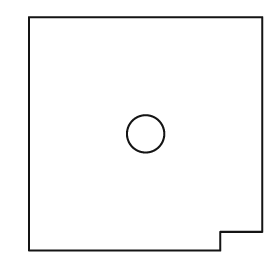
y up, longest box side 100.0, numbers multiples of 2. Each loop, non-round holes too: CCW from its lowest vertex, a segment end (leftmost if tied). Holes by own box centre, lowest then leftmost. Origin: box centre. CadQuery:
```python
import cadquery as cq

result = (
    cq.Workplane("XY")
    .moveTo(-50.0, -50.0)
    .lineTo(32.0, -50.0)
    .lineTo(32.0, -42.0)
    .lineTo(50.0, -42.0)
    .lineTo(50.0, 50.0)
    .lineTo(-50.0, 50.0)
    .close()
    .moveTo(0.0, 0.0)
    .circle(8.0)
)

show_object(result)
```